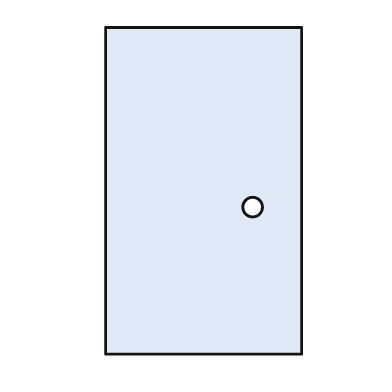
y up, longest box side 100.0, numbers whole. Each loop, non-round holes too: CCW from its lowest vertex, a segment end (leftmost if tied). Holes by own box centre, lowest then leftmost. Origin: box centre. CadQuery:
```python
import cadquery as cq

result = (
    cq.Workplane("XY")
    .moveTo(-30.0, -50.0)
    .lineTo(30.0, -50.0)
    .lineTo(30.0, 50.0)
    .lineTo(-30.0, 50.0)
    .close()
    .moveTo(15.0, -5.0)
    .circle(3.0)
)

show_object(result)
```